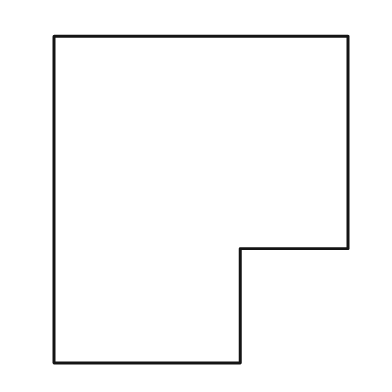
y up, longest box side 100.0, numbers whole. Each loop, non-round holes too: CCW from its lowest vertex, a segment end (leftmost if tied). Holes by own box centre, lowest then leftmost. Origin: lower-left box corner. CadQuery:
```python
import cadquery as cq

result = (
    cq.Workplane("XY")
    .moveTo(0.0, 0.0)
    .lineTo(57.0, 0.0)
    .lineTo(57.0, 35.0)
    .lineTo(90.0, 35.0)
    .lineTo(90.0, 100.0)
    .lineTo(0.0, 100.0)
    .close()
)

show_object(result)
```